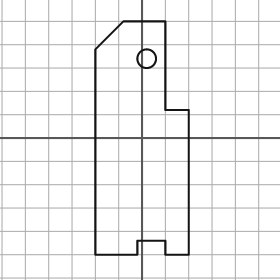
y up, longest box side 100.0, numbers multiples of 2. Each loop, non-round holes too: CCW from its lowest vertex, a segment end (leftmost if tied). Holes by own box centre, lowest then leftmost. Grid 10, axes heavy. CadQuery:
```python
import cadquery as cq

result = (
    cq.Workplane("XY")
    .moveTo(-20.0, -50.0)
    .lineTo(-2.0, -50.0)
    .lineTo(-2.0, -44.0)
    .lineTo(10.0, -44.0)
    .lineTo(10.0, -50.0)
    .lineTo(20.0, -50.0)
    .lineTo(20.0, 12.0)
    .lineTo(10.0, 12.0)
    .lineTo(10.0, 50.0)
    .lineTo(-8.0, 50.0)
    .lineTo(-20.0, 38.0)
    .close()
    .moveTo(2.0, 34.0)
    .circle(4.0)
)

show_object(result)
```